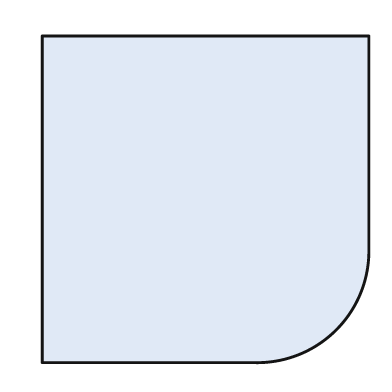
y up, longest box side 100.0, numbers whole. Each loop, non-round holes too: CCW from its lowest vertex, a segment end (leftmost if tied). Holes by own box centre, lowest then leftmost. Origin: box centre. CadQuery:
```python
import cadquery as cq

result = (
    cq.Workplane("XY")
    .moveTo(-50.0, -50.0)
    .lineTo(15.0, -50.0)
    .threePointArc((40.0, -40.0), (50.0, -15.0))
    .lineTo(50.0, 50.0)
    .lineTo(-50.0, 50.0)
    .close()
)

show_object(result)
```